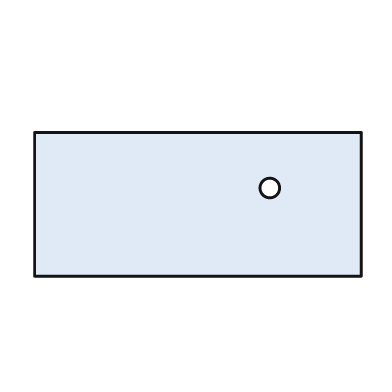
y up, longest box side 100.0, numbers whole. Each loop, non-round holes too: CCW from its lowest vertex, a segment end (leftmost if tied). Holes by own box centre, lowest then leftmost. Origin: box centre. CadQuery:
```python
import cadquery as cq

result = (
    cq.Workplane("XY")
    .moveTo(-50.0, -22.0)
    .lineTo(50.0, -22.0)
    .lineTo(50.0, 22.0)
    .lineTo(-50.0, 22.0)
    .close()
    .moveTo(22.0, 5.0)
    .circle(3.0)
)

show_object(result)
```